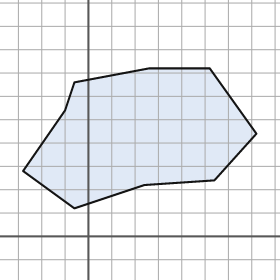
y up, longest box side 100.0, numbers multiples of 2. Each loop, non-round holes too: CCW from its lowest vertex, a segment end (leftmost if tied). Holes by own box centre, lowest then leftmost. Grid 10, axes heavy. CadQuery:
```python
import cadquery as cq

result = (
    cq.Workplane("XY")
    .moveTo(-6.0, 12.0)
    .lineTo(24.0, 22.0)
    .lineTo(54.0, 24.0)
    .lineTo(72.0, 44.0)
    .lineTo(52.0, 72.0)
    .lineTo(26.0, 72.0)
    .lineTo(-6.0, 66.0)
    .lineTo(-10.0, 54.0)
    .lineTo(-28.0, 28.0)
    .close()
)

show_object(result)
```